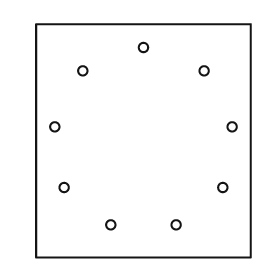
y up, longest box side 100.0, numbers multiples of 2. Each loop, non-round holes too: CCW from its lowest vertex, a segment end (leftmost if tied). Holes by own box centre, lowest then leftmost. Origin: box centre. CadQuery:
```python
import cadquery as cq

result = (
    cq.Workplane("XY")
    .moveTo(-46.0, -50.0)
    .lineTo(46.0, -50.0)
    .lineTo(46.0, 50.0)
    .lineTo(-46.0, 50.0)
    .close()
    .moveTo(-14.0, -36.0)
    .circle(2.0)
    .moveTo(14.0, -36.0)
    .circle(2.0)
    .moveTo(-34.0, -20.0)
    .circle(2.0)
    .moveTo(34.0, -20.0)
    .circle(2.0)
    .moveTo(-38.0, 6.0)
    .circle(2.0)
    .moveTo(38.0, 6.0)
    .circle(2.0)
    .moveTo(-26.0, 30.0)
    .circle(2.0)
    .moveTo(26.0, 30.0)
    .circle(2.0)
    .moveTo(0.0, 40.0)
    .circle(2.0)
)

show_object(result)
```